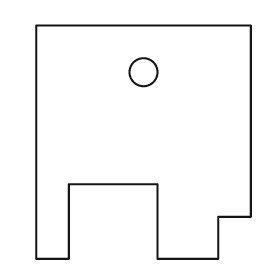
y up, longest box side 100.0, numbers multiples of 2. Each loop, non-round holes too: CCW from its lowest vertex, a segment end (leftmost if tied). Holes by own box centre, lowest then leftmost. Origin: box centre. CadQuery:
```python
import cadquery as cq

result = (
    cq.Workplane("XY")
    .moveTo(-46.0, -50.0)
    .lineTo(-32.0, -50.0)
    .lineTo(-32.0, -18.0)
    .lineTo(6.0, -18.0)
    .lineTo(6.0, -50.0)
    .lineTo(32.0, -50.0)
    .lineTo(32.0, -32.0)
    .lineTo(46.0, -32.0)
    .lineTo(46.0, 50.0)
    .lineTo(-46.0, 50.0)
    .close()
    .moveTo(0.0, 30.0)
    .circle(6.0)
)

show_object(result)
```